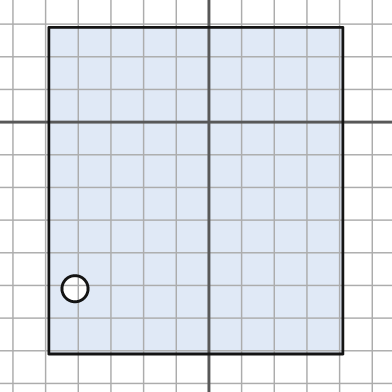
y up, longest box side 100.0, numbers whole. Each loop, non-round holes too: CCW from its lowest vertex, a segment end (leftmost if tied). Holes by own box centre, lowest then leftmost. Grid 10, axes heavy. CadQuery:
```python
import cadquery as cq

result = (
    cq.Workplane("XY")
    .moveTo(-49.0, -71.0)
    .lineTo(41.0, -71.0)
    .lineTo(41.0, 29.0)
    .lineTo(-49.0, 29.0)
    .close()
    .moveTo(-41.0, -51.0)
    .circle(4.0)
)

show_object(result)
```